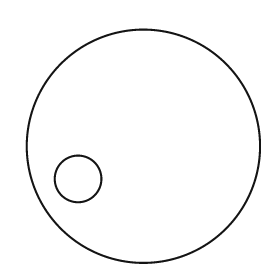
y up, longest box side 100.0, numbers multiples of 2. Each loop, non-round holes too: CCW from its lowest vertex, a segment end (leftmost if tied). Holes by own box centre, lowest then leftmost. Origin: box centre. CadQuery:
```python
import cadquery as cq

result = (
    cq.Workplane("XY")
    .moveTo(0.0, 0.0)
    .circle(50.0)
    .moveTo(-28.0, -14.0)
    .circle(10.0)
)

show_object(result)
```